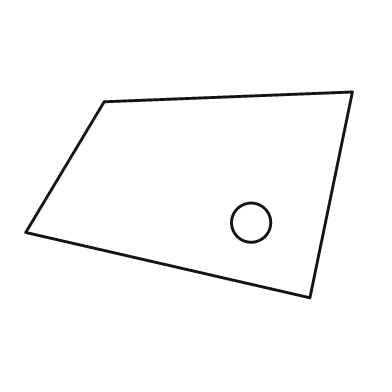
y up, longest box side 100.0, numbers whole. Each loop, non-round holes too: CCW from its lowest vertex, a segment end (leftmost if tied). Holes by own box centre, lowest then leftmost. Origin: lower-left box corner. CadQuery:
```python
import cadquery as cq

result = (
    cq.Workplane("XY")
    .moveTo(87.0, 0.0)
    .lineTo(100.0, 63.0)
    .lineTo(24.0, 60.0)
    .lineTo(0.0, 20.0)
    .close()
    .moveTo(69.0, 23.0)
    .circle(6.0)
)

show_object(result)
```